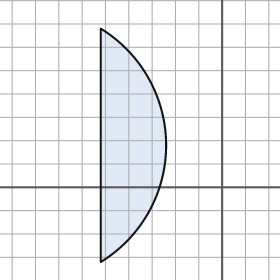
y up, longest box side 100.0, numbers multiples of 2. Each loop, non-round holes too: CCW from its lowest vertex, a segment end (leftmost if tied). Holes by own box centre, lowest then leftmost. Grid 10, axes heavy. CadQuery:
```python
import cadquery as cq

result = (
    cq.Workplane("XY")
    .moveTo(-52.0, -32.0)
    .threePointArc((-24.0, 18.0), (-52.0, 68.0))
    .close()
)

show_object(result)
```